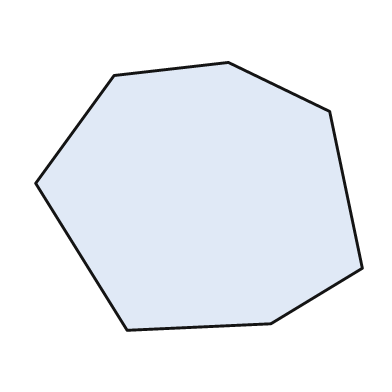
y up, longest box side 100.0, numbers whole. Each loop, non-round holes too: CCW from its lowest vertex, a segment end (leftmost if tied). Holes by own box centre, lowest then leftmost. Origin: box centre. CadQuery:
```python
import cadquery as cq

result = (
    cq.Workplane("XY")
    .moveTo(-22.0, -41.0)
    .lineTo(22.0, -39.0)
    .lineTo(50.0, -22.0)
    .lineTo(40.0, 26.0)
    .lineTo(9.0, 41.0)
    .lineTo(-26.0, 37.0)
    .lineTo(-50.0, 4.0)
    .close()
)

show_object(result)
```